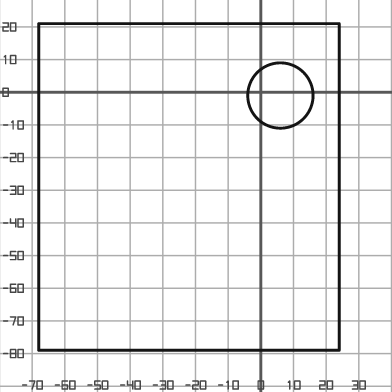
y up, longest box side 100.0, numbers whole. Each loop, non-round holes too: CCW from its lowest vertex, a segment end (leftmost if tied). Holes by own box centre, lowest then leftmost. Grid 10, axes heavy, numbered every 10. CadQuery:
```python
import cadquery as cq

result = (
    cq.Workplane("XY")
    .moveTo(-68.0, -79.0)
    .lineTo(24.0, -79.0)
    .lineTo(24.0, 21.0)
    .lineTo(-68.0, 21.0)
    .close()
    .moveTo(6.0, -1.0)
    .circle(10.0)
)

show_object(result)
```